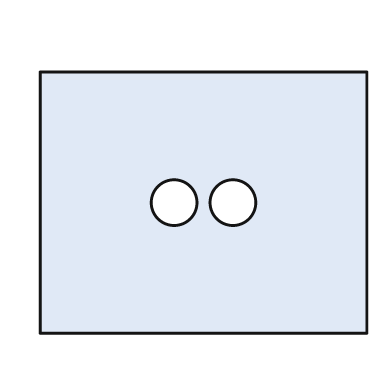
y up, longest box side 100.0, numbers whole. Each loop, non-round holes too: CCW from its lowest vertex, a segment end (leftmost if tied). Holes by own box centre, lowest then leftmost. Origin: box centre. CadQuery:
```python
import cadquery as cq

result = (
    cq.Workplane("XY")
    .moveTo(-50.0, -40.0)
    .lineTo(50.0, -40.0)
    .lineTo(50.0, 40.0)
    .lineTo(-50.0, 40.0)
    .close()
    .moveTo(-9.0, 0.0)
    .circle(7.0)
    .moveTo(9.0, 0.0)
    .circle(7.0)
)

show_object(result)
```